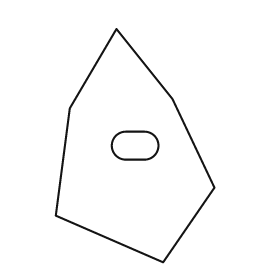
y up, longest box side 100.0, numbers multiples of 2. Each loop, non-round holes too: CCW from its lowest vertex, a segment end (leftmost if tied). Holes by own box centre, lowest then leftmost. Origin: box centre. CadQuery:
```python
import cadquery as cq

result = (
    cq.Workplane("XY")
    .moveTo(12.0, -50.0)
    .lineTo(34.0, -18.0)
    .lineTo(16.0, 20.0)
    .lineTo(-8.0, 50.0)
    .lineTo(-28.0, 16.0)
    .lineTo(-34.0, -30.0)
    .close()
    .moveTo(-4.0, -6.0)
    .lineTo(4.0, -6.0)
    .threePointArc((10.0, 0.0), (4.0, 6.0))
    .lineTo(-4.0, 6.0)
    .threePointArc((-10.0, 0.0), (-4.0, -6.0))
    .close()
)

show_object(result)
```